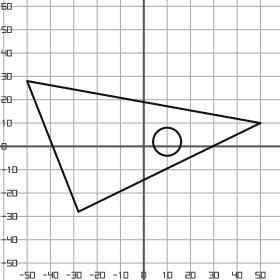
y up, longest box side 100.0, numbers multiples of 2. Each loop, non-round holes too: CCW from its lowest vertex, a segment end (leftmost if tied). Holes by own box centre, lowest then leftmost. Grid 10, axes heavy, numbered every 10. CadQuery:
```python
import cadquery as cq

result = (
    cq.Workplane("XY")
    .moveTo(-28.0, -28.0)
    .lineTo(50.0, 10.0)
    .lineTo(-50.0, 28.0)
    .close()
    .moveTo(10.0, 2.0)
    .circle(6.0)
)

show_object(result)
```